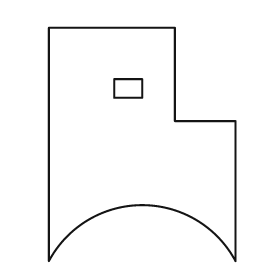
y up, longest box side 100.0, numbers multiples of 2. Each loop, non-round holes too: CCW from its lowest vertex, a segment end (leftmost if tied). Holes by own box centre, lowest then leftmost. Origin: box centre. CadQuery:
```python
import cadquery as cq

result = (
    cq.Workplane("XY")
    .moveTo(-40.0, -50.0)
    .threePointArc((0.0, -26.0), (40.0, -50.0))
    .lineTo(40.0, 10.0)
    .lineTo(14.0, 10.0)
    .lineTo(14.0, 50.0)
    .lineTo(-40.0, 50.0)
    .close()
    .moveTo(-12.0, 20.0)
    .lineTo(0.0, 20.0)
    .lineTo(0.0, 28.0)
    .lineTo(-12.0, 28.0)
    .close()
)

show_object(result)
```